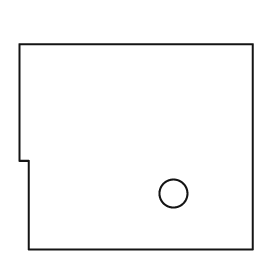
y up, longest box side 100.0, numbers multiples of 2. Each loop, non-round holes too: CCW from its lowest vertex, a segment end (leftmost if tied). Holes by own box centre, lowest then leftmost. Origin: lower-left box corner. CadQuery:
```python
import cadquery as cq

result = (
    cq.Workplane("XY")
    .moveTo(4.0, 0.0)
    .lineTo(100.0, 0.0)
    .lineTo(100.0, 88.0)
    .lineTo(0.0, 88.0)
    .lineTo(0.0, 38.0)
    .lineTo(4.0, 38.0)
    .close()
    .moveTo(66.0, 24.0)
    .circle(6.0)
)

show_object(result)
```